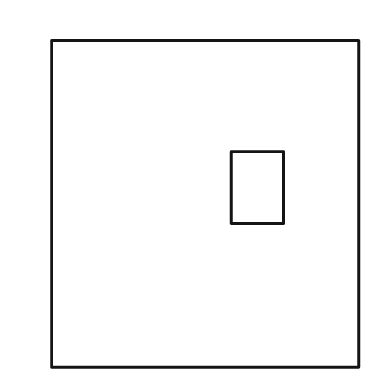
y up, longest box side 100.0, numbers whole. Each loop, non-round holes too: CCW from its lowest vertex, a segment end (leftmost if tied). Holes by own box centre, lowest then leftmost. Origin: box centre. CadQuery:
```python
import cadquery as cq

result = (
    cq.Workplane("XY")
    .moveTo(-47.0, -50.0)
    .lineTo(47.0, -50.0)
    .lineTo(47.0, 50.0)
    .lineTo(-47.0, 50.0)
    .close()
    .moveTo(8.0, -6.0)
    .lineTo(24.0, -6.0)
    .lineTo(24.0, 16.0)
    .lineTo(8.0, 16.0)
    .close()
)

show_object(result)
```